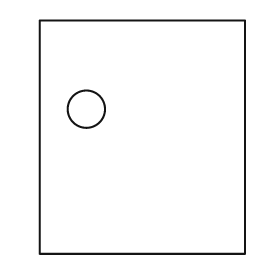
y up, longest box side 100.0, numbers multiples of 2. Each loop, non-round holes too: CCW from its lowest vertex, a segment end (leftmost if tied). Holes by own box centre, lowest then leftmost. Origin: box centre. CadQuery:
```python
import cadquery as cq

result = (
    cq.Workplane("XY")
    .moveTo(-44.0, -50.0)
    .lineTo(44.0, -50.0)
    .lineTo(44.0, 50.0)
    .lineTo(-44.0, 50.0)
    .close()
    .moveTo(-24.0, 12.0)
    .circle(8.0)
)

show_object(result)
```